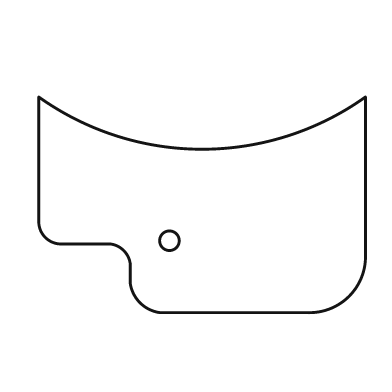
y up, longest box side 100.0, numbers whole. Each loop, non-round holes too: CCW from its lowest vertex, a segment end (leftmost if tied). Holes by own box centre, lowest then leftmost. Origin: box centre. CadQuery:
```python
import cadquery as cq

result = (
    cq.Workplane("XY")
    .moveTo(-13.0, -33.0)
    .lineTo(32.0, -33.0)
    .threePointArc((45.0, -28.0), (50.0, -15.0))
    .lineTo(50.0, 33.0)
    .threePointArc((0.0, 17.0), (-50.0, 33.0))
    .lineTo(-50.0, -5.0)
    .threePointArc((-48.0, -10.0), (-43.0, -12.0))
    .lineTo(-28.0, -12.0)
    .threePointArc((-24.0, -14.0), (-22.0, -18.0))
    .lineTo(-22.0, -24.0)
    .threePointArc((-19.0, -30.0), (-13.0, -33.0))
    .close()
    .moveTo(-10.0, -11.0)
    .circle(3.0)
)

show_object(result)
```